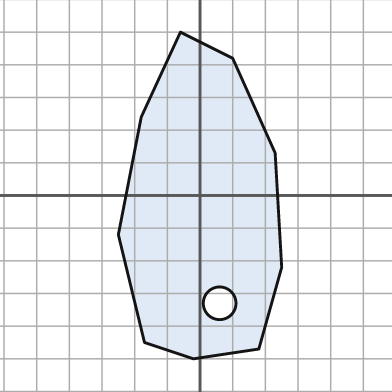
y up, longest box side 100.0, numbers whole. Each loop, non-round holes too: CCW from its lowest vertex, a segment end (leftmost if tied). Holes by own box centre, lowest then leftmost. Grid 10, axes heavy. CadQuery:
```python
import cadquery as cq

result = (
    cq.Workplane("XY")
    .moveTo(-2.0, -50.0)
    .lineTo(18.0, -47.0)
    .lineTo(25.0, -22.0)
    .lineTo(23.0, 13.0)
    .lineTo(10.0, 42.0)
    .lineTo(-6.0, 50.0)
    .lineTo(-18.0, 24.0)
    .lineTo(-25.0, -12.0)
    .lineTo(-17.0, -45.0)
    .close()
    .moveTo(6.0, -33.0)
    .circle(5.0)
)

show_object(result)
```